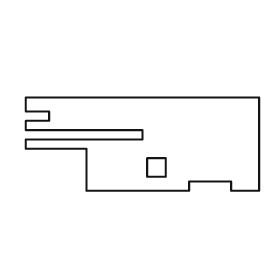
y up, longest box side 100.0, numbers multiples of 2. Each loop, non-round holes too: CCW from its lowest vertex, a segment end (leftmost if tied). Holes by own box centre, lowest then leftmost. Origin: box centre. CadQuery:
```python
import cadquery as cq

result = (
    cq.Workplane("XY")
    .moveTo(-24.0, -20.0)
    .lineTo(20.0, -20.0)
    .lineTo(20.0, -16.0)
    .lineTo(38.0, -16.0)
    .lineTo(38.0, -20.0)
    .lineTo(50.0, -20.0)
    .lineTo(50.0, 20.0)
    .lineTo(-50.0, 20.0)
    .lineTo(-50.0, 14.0)
    .lineTo(-40.0, 14.0)
    .lineTo(-40.0, 10.0)
    .lineTo(-50.0, 10.0)
    .lineTo(-50.0, 6.0)
    .lineTo(0.0, 6.0)
    .lineTo(0.0, 2.0)
    .lineTo(-50.0, 2.0)
    .lineTo(-50.0, -2.0)
    .lineTo(-24.0, -2.0)
    .close()
    .moveTo(2.0, -14.0)
    .lineTo(10.0, -14.0)
    .lineTo(10.0, -6.0)
    .lineTo(2.0, -6.0)
    .close()
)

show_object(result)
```